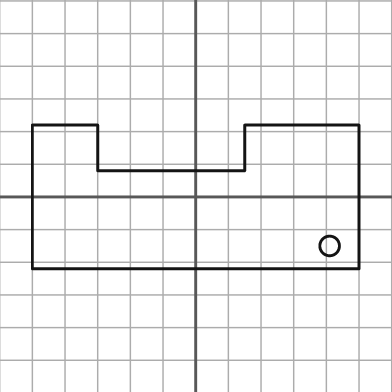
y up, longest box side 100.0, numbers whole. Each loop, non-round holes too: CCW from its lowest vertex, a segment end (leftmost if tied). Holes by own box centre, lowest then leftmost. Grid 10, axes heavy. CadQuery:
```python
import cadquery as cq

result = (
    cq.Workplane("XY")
    .moveTo(-50.0, -22.0)
    .lineTo(50.0, -22.0)
    .lineTo(50.0, 22.0)
    .lineTo(15.0, 22.0)
    .lineTo(15.0, 8.0)
    .lineTo(-30.0, 8.0)
    .lineTo(-30.0, 22.0)
    .lineTo(-50.0, 22.0)
    .close()
    .moveTo(41.0, -15.0)
    .circle(3.0)
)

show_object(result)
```